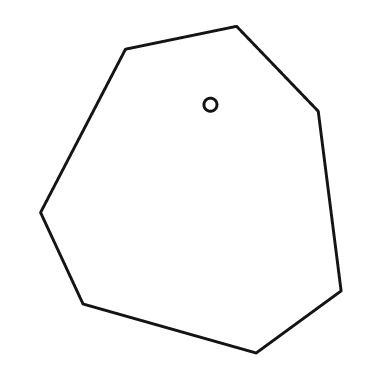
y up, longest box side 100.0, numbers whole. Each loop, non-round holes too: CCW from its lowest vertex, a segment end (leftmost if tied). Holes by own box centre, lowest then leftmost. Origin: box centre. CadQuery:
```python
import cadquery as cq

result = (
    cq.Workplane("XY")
    .moveTo(20.0, -50.0)
    .lineTo(46.0, -31.0)
    .lineTo(39.0, 24.0)
    .lineTo(14.0, 50.0)
    .lineTo(-20.0, 43.0)
    .lineTo(-46.0, -7.0)
    .lineTo(-33.0, -35.0)
    .close()
    .moveTo(6.0, 26.0)
    .circle(2.0)
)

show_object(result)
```